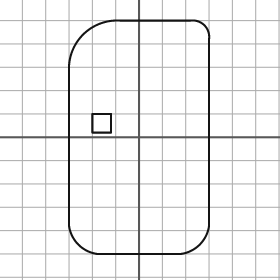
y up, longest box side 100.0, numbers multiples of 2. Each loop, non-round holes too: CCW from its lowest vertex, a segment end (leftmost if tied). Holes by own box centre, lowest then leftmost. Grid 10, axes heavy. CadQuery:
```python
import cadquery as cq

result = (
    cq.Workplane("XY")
    .moveTo(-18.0, -50.0)
    .lineTo(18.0, -50.0)
    .threePointArc((26.0, -46.0), (30.0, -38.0))
    .lineTo(30.0, 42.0)
    .threePointArc((28.0, 48.0), (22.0, 50.0))
    .lineTo(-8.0, 50.0)
    .threePointArc((-24.0, 44.0), (-30.0, 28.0))
    .lineTo(-30.0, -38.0)
    .threePointArc((-26.0, -46.0), (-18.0, -50.0))
    .close()
    .moveTo(-20.0, 2.0)
    .lineTo(-12.0, 2.0)
    .lineTo(-12.0, 10.0)
    .lineTo(-20.0, 10.0)
    .close()
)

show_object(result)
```